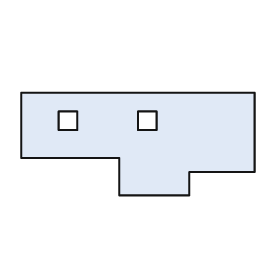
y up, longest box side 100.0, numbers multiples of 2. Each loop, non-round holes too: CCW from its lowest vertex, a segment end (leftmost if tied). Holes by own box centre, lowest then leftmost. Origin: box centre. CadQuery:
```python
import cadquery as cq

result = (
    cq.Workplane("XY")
    .moveTo(-8.0, -22.0)
    .lineTo(22.0, -22.0)
    .lineTo(22.0, -12.0)
    .lineTo(50.0, -12.0)
    .lineTo(50.0, 22.0)
    .lineTo(-50.0, 22.0)
    .lineTo(-50.0, -6.0)
    .lineTo(-8.0, -6.0)
    .close()
    .moveTo(-34.0, 6.0)
    .lineTo(-26.0, 6.0)
    .lineTo(-26.0, 14.0)
    .lineTo(-34.0, 14.0)
    .close()
    .moveTo(0.0, 6.0)
    .lineTo(8.0, 6.0)
    .lineTo(8.0, 14.0)
    .lineTo(0.0, 14.0)
    .close()
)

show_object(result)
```